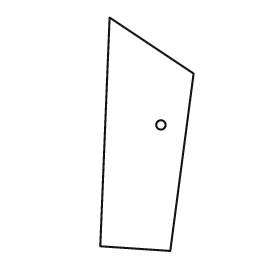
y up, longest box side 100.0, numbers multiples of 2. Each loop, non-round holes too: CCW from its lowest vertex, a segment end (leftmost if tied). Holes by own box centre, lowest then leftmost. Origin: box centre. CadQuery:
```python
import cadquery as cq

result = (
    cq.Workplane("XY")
    .moveTo(10.0, -50.0)
    .lineTo(20.0, 26.0)
    .lineTo(-16.0, 50.0)
    .lineTo(-20.0, -48.0)
    .close()
    .moveTo(6.0, 4.0)
    .circle(2.0)
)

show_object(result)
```